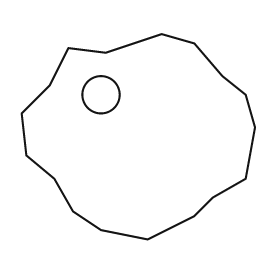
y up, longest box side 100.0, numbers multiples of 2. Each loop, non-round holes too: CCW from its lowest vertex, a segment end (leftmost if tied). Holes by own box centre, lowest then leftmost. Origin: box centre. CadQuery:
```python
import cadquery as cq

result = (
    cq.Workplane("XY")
    .moveTo(4.0, -44.0)
    .lineTo(24.0, -34.0)
    .lineTo(32.0, -26.0)
    .lineTo(46.0, -18.0)
    .lineTo(50.0, 4.0)
    .lineTo(46.0, 18.0)
    .lineTo(36.0, 26.0)
    .lineTo(24.0, 40.0)
    .lineTo(10.0, 44.0)
    .lineTo(-14.0, 36.0)
    .lineTo(-30.0, 38.0)
    .lineTo(-38.0, 22.0)
    .lineTo(-50.0, 10.0)
    .lineTo(-48.0, -8.0)
    .lineTo(-36.0, -18.0)
    .lineTo(-28.0, -32.0)
    .lineTo(-16.0, -40.0)
    .close()
    .moveTo(-16.0, 18.0)
    .circle(8.0)
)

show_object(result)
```